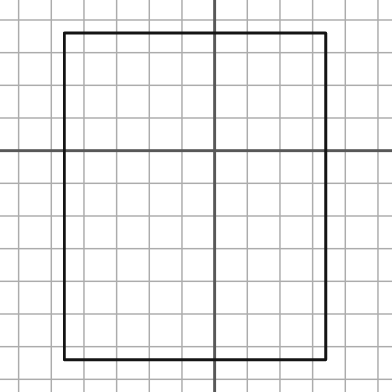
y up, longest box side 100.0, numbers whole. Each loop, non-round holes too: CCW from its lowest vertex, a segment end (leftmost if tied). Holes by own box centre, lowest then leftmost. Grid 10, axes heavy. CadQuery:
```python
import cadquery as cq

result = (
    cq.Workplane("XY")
    .moveTo(-46.0, -64.0)
    .lineTo(34.0, -64.0)
    .lineTo(34.0, 36.0)
    .lineTo(-46.0, 36.0)
    .close()
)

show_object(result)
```